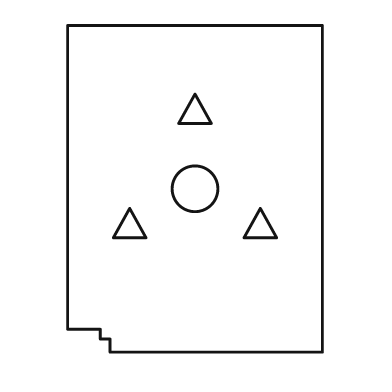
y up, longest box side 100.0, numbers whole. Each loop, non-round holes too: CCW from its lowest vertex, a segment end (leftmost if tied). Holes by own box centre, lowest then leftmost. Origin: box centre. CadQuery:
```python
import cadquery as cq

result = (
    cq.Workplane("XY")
    .moveTo(-26.0, -50.0)
    .lineTo(39.0, -50.0)
    .lineTo(39.0, 50.0)
    .lineTo(-39.0, 50.0)
    .lineTo(-39.0, -43.0)
    .lineTo(-29.0, -43.0)
    .lineTo(-29.0, -46.0)
    .lineTo(-26.0, -46.0)
    .close()
    .moveTo(-25.0, -15.0)
    .lineTo(-15.0, -15.0)
    .lineTo(-20.0, -6.0)
    .close()
    .moveTo(15.0, -15.0)
    .lineTo(25.0, -15.0)
    .lineTo(20.0, -6.0)
    .close()
    .moveTo(0.0, 0.0)
    .circle(7.0)
    .moveTo(-5.0, 20.0)
    .lineTo(5.0, 20.0)
    .lineTo(0.0, 29.0)
    .close()
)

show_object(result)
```